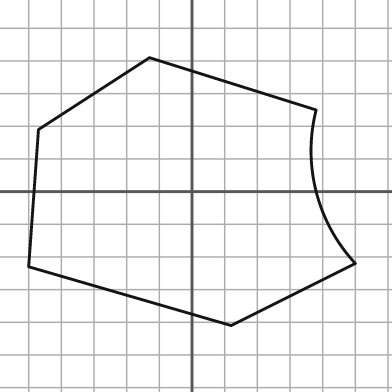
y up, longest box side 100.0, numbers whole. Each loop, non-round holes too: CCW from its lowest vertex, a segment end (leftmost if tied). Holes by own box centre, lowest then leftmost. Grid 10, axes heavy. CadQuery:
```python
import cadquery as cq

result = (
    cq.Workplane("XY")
    .moveTo(12.0, -41.0)
    .lineTo(50.0, -22.0)
    .threePointArc((38.0, 0.0), (38.0, 25.0))
    .lineTo(-13.0, 41.0)
    .lineTo(-47.0, 19.0)
    .lineTo(-50.0, -23.0)
    .close()
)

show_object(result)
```